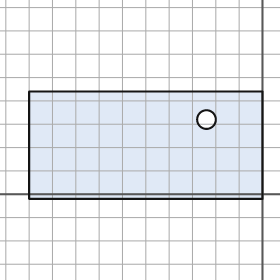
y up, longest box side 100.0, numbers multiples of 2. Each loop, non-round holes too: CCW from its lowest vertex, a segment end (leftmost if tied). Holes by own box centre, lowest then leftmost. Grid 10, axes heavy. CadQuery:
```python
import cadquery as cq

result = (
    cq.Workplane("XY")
    .moveTo(-100.0, -2.0)
    .lineTo(0.0, -2.0)
    .lineTo(0.0, 44.0)
    .lineTo(-100.0, 44.0)
    .close()
    .moveTo(-24.0, 32.0)
    .circle(4.0)
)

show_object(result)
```